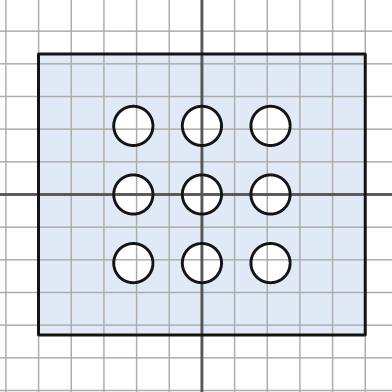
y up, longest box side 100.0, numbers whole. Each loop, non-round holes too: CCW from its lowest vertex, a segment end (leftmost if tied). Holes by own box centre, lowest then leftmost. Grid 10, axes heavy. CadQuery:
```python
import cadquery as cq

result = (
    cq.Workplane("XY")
    .moveTo(-50.0, -43.0)
    .lineTo(50.0, -43.0)
    .lineTo(50.0, 43.0)
    .lineTo(-50.0, 43.0)
    .close()
    .moveTo(-21.0, -21.0)
    .circle(6.0)
    .moveTo(0.0, -21.0)
    .circle(6.0)
    .moveTo(21.0, -21.0)
    .circle(6.0)
    .moveTo(-21.0, 0.0)
    .circle(6.0)
    .moveTo(0.0, 0.0)
    .circle(6.0)
    .moveTo(21.0, 0.0)
    .circle(6.0)
    .moveTo(-21.0, 21.0)
    .circle(6.0)
    .moveTo(0.0, 21.0)
    .circle(6.0)
    .moveTo(21.0, 21.0)
    .circle(6.0)
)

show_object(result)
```